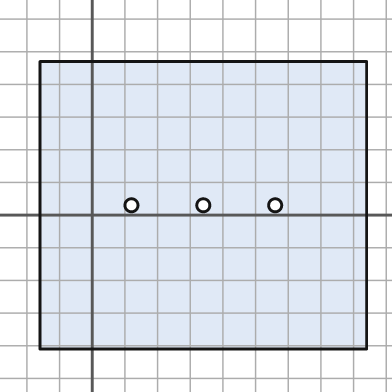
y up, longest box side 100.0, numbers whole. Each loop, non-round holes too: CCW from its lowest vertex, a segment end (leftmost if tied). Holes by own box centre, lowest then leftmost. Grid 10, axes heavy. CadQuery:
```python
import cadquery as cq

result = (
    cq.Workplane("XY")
    .moveTo(-16.0, -41.0)
    .lineTo(84.0, -41.0)
    .lineTo(84.0, 47.0)
    .lineTo(-16.0, 47.0)
    .close()
    .moveTo(12.0, 3.0)
    .circle(2.0)
    .moveTo(34.0, 3.0)
    .circle(2.0)
    .moveTo(56.0, 3.0)
    .circle(2.0)
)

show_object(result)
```